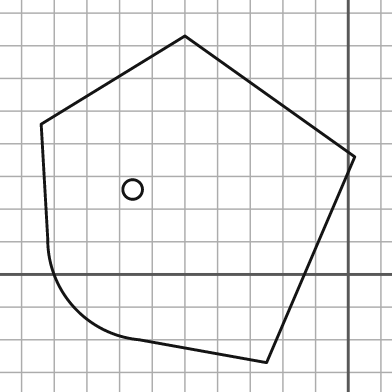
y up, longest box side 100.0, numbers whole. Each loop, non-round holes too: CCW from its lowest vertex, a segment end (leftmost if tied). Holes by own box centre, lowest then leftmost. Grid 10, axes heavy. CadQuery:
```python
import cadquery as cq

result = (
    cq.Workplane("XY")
    .moveTo(-25.0, -27.0)
    .lineTo(2.0, 36.0)
    .lineTo(-50.0, 73.0)
    .lineTo(-94.0, 46.0)
    .lineTo(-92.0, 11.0)
    .threePointArc((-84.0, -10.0), (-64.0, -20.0))
    .close()
    .moveTo(-66.0, 26.0)
    .circle(3.0)
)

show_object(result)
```